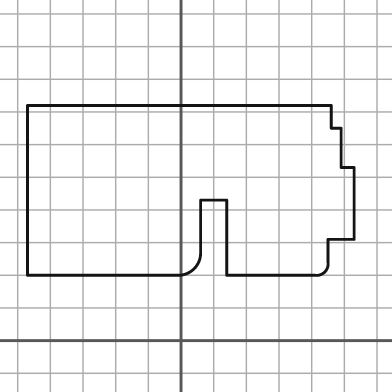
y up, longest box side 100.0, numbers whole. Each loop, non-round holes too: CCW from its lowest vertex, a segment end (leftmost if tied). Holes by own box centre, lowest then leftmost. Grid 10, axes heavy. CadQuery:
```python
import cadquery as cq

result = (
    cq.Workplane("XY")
    .moveTo(-47.0, 20.0)
    .lineTo(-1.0, 20.0)
    .threePointArc((4.0, 22.0), (6.0, 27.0))
    .lineTo(6.0, 43.0)
    .lineTo(14.0, 43.0)
    .lineTo(14.0, 20.0)
    .lineTo(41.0, 20.0)
    .threePointArc((44.0, 21.0), (45.0, 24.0))
    .lineTo(45.0, 31.0)
    .lineTo(53.0, 31.0)
    .lineTo(53.0, 53.0)
    .lineTo(49.0, 53.0)
    .lineTo(49.0, 65.0)
    .lineTo(46.0, 65.0)
    .lineTo(46.0, 72.0)
    .lineTo(-47.0, 72.0)
    .close()
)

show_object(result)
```